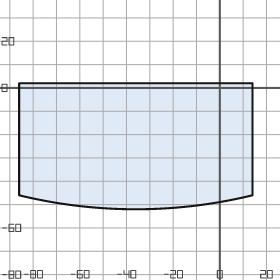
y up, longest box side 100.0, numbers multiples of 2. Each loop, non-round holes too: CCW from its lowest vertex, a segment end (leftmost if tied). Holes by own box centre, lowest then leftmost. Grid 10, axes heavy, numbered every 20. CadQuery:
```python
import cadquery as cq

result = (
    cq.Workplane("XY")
    .moveTo(-86.0, -46.0)
    .threePointArc((-36.0, -52.0), (14.0, -46.0))
    .lineTo(14.0, 2.0)
    .lineTo(-86.0, 2.0)
    .close()
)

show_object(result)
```